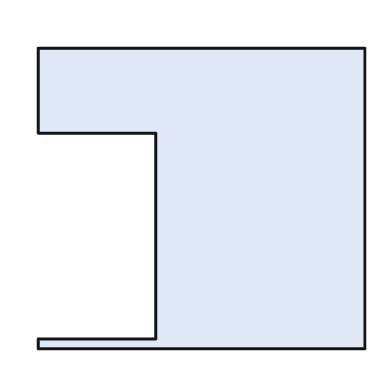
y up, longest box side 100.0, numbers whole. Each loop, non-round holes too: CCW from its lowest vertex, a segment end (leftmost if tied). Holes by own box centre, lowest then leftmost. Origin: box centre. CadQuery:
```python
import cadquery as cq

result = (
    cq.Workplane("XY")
    .moveTo(-50.0, -46.0)
    .lineTo(50.0, -46.0)
    .lineTo(50.0, 46.0)
    .lineTo(-50.0, 46.0)
    .lineTo(-50.0, 20.0)
    .lineTo(-14.0, 20.0)
    .lineTo(-14.0, -43.0)
    .lineTo(-50.0, -43.0)
    .close()
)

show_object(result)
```